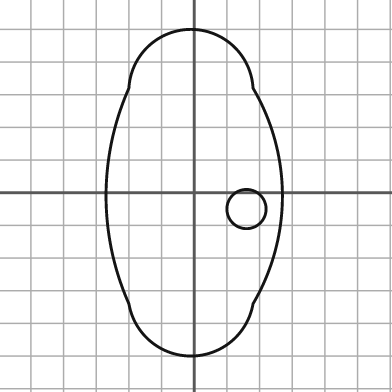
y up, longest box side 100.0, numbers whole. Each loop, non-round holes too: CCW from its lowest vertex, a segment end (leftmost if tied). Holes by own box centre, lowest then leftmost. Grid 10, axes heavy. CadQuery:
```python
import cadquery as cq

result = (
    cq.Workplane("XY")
    .moveTo(-20.0, -34.0)
    .threePointArc((-1.0, -50.0), (18.0, -34.0))
    .threePointArc((27.0, -1.0), (18.0, 32.0))
    .threePointArc((-1.0, 50.0), (-20.0, 32.0))
    .threePointArc((-27.0, -1.0), (-20.0, -34.0))
    .close()
    .moveTo(16.0, -5.0)
    .circle(6.0)
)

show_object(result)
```